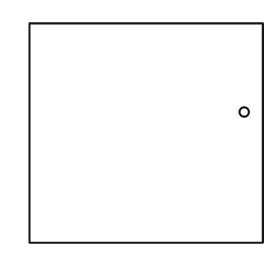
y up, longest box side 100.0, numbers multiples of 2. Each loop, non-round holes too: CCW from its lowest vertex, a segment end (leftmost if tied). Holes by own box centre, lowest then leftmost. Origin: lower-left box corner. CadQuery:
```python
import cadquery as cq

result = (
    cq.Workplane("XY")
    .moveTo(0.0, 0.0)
    .lineTo(100.0, 0.0)
    .lineTo(100.0, 94.0)
    .lineTo(0.0, 94.0)
    .close()
    .moveTo(92.0, 56.0)
    .circle(2.0)
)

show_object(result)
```